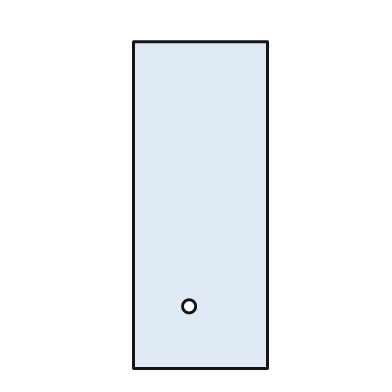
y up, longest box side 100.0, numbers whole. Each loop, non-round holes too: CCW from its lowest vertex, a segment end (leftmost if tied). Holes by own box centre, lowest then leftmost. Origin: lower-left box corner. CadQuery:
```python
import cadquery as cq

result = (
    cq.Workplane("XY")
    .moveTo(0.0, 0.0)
    .lineTo(41.0, 0.0)
    .lineTo(41.0, 100.0)
    .lineTo(0.0, 100.0)
    .close()
    .moveTo(17.0, 19.0)
    .circle(2.0)
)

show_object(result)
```